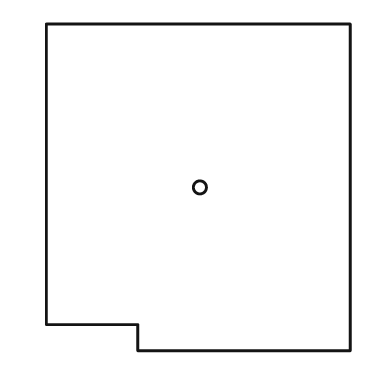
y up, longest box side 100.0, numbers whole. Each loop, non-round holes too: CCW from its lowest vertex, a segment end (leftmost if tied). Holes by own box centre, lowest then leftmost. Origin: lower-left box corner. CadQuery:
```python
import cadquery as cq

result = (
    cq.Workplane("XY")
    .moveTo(28.0, 0.0)
    .lineTo(93.0, 0.0)
    .lineTo(93.0, 100.0)
    .lineTo(0.0, 100.0)
    .lineTo(0.0, 8.0)
    .lineTo(28.0, 8.0)
    .close()
    .moveTo(47.0, 50.0)
    .circle(2.0)
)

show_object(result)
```